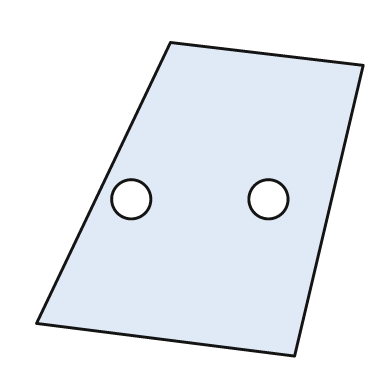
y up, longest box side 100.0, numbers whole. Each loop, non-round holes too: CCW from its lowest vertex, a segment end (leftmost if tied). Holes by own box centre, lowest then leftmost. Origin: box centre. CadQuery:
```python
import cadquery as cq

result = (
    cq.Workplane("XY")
    .moveTo(29.0, -48.0)
    .lineTo(50.0, 41.0)
    .lineTo(-9.0, 48.0)
    .lineTo(-50.0, -38.0)
    .close()
    .moveTo(-21.0, 0.0)
    .circle(6.0)
    .moveTo(21.0, 0.0)
    .circle(6.0)
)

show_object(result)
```